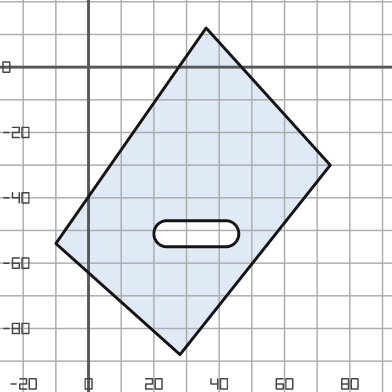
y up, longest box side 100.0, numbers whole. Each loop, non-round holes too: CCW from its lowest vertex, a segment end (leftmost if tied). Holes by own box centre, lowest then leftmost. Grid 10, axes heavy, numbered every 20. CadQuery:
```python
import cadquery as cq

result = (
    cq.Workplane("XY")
    .moveTo(28.0, -88.0)
    .lineTo(74.0, -30.0)
    .lineTo(36.0, 12.0)
    .lineTo(-10.0, -54.0)
    .close()
    .moveTo(24.0, -55.0)
    .lineTo(42.0, -55.0)
    .threePointArc((46.0, -51.0), (42.0, -47.0))
    .lineTo(24.0, -47.0)
    .threePointArc((20.0, -51.0), (24.0, -55.0))
    .close()
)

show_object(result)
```